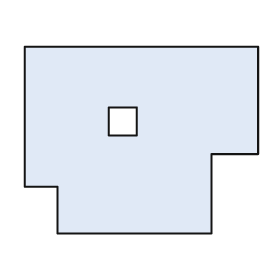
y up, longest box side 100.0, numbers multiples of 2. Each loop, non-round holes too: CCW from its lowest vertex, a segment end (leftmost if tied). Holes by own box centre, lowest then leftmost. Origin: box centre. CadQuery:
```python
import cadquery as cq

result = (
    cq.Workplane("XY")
    .moveTo(-36.0, -40.0)
    .lineTo(30.0, -40.0)
    .lineTo(30.0, -6.0)
    .lineTo(50.0, -6.0)
    .lineTo(50.0, 40.0)
    .lineTo(-50.0, 40.0)
    .lineTo(-50.0, -20.0)
    .lineTo(-36.0, -20.0)
    .close()
    .moveTo(-14.0, 2.0)
    .lineTo(-2.0, 2.0)
    .lineTo(-2.0, 14.0)
    .lineTo(-14.0, 14.0)
    .close()
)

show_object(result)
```